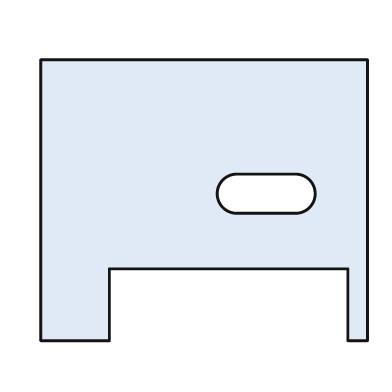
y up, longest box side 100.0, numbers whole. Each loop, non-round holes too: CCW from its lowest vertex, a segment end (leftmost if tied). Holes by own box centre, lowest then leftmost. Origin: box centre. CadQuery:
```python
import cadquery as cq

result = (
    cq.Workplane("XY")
    .moveTo(-50.0, -43.0)
    .lineTo(-29.0, -43.0)
    .lineTo(-29.0, -21.0)
    .lineTo(44.0, -21.0)
    .lineTo(44.0, -43.0)
    .lineTo(50.0, -43.0)
    .lineTo(50.0, 43.0)
    .lineTo(-50.0, 43.0)
    .close()
    .moveTo(10.0, -4.0)
    .lineTo(28.0, -4.0)
    .threePointArc((34.0, 2.0), (28.0, 8.0))
    .lineTo(10.0, 8.0)
    .threePointArc((4.0, 2.0), (10.0, -4.0))
    .close()
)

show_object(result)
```